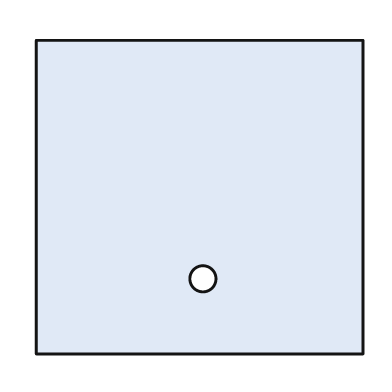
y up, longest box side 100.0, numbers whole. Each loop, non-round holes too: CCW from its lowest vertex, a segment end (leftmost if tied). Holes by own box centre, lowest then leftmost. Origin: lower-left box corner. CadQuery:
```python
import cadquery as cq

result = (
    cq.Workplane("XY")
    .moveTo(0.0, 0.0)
    .lineTo(100.0, 0.0)
    .lineTo(100.0, 96.0)
    .lineTo(0.0, 96.0)
    .close()
    .moveTo(51.0, 23.0)
    .circle(4.0)
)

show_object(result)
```